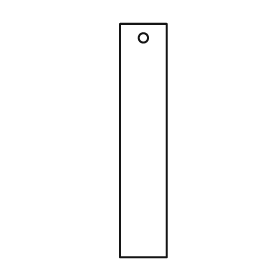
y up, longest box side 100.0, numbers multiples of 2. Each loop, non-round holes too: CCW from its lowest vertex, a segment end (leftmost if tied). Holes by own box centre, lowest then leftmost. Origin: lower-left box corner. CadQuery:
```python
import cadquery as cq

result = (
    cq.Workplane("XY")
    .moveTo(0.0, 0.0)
    .lineTo(20.0, 0.0)
    .lineTo(20.0, 100.0)
    .lineTo(0.0, 100.0)
    .close()
    .moveTo(10.0, 94.0)
    .circle(2.0)
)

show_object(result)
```